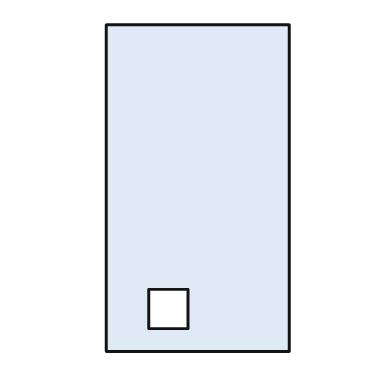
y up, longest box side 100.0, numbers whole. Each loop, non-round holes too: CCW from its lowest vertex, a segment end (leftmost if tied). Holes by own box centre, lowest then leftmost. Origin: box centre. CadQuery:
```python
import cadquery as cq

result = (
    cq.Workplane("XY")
    .moveTo(-28.0, -50.0)
    .lineTo(28.0, -50.0)
    .lineTo(28.0, 50.0)
    .lineTo(-28.0, 50.0)
    .close()
    .moveTo(-15.0, -43.0)
    .lineTo(-3.0, -43.0)
    .lineTo(-3.0, -31.0)
    .lineTo(-15.0, -31.0)
    .close()
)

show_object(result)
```